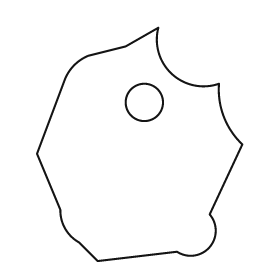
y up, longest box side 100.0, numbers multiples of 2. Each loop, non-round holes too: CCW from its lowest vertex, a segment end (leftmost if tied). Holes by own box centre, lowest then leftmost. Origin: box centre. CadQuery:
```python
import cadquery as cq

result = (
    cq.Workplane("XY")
    .moveTo(-18.0, -50.0)
    .lineTo(16.0, -46.0)
    .threePointArc((30.0, -44.0), (30.0, -30.0))
    .lineTo(44.0, 0.0)
    .threePointArc((36.0, 12.0), (34.0, 26.0))
    .threePointArc((14.0, 30.0), (8.0, 50.0))
    .lineTo(-6.0, 42.0)
    .lineTo(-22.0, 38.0)
    .threePointArc((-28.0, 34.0), (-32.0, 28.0))
    .lineTo(-44.0, -4.0)
    .lineTo(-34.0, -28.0)
    .threePointArc((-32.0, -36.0), (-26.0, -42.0))
    .close()
    .moveTo(2.0, 18.0)
    .circle(8.0)
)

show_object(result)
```